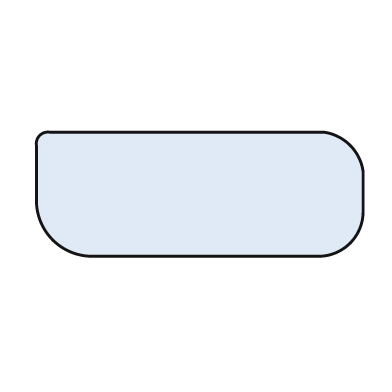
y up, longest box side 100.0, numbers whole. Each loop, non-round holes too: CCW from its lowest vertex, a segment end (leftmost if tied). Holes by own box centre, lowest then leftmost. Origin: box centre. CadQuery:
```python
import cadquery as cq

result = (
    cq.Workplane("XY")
    .moveTo(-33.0, -19.0)
    .lineTo(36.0, -19.0)
    .threePointArc((46.0, -15.0), (50.0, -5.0))
    .lineTo(50.0, 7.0)
    .threePointArc((46.0, 15.0), (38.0, 19.0))
    .lineTo(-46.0, 19.0)
    .threePointArc((-49.0, 18.0), (-50.0, 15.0))
    .lineTo(-50.0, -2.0)
    .threePointArc((-45.0, -14.0), (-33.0, -19.0))
    .close()
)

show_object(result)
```